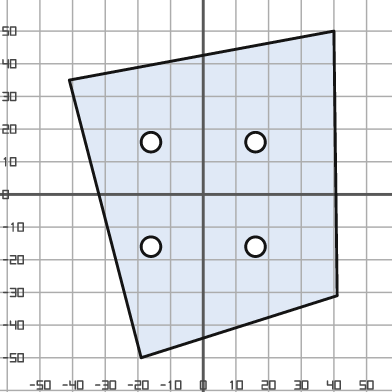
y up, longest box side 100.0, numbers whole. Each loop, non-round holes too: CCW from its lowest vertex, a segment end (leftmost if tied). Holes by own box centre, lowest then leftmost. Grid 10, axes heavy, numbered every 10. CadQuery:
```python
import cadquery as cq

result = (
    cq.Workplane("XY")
    .moveTo(-19.0, -50.0)
    .lineTo(41.0, -31.0)
    .lineTo(40.0, 50.0)
    .lineTo(-41.0, 35.0)
    .close()
    .moveTo(-16.0, -16.0)
    .circle(3.0)
    .moveTo(16.0, -16.0)
    .circle(3.0)
    .moveTo(-16.0, 16.0)
    .circle(3.0)
    .moveTo(16.0, 16.0)
    .circle(3.0)
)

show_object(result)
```